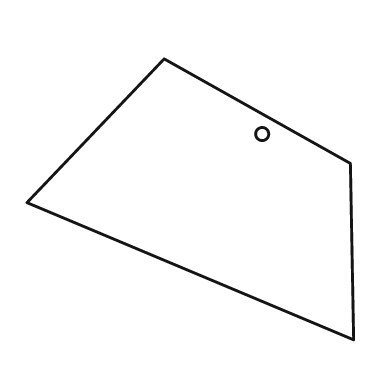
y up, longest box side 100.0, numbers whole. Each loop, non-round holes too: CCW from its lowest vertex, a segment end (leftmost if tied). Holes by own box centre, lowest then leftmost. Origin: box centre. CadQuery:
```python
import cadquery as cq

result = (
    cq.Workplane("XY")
    .moveTo(50.0, -43.0)
    .lineTo(49.0, 11.0)
    .lineTo(-8.0, 43.0)
    .lineTo(-50.0, -1.0)
    .close()
    .moveTo(22.0, 20.0)
    .circle(2.0)
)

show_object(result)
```